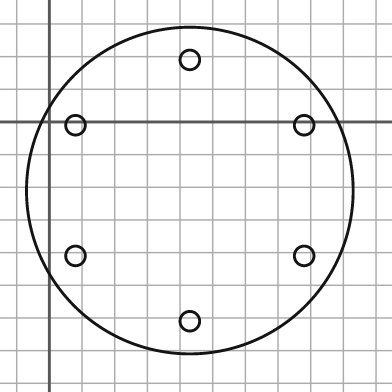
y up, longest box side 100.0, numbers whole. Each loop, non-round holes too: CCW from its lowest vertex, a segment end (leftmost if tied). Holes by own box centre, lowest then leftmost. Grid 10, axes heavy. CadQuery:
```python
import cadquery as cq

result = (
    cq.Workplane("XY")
    .moveTo(43.0, -21.0)
    .circle(50.0)
    .moveTo(43.0, -61.0)
    .circle(3.0)
    .moveTo(8.0, -41.0)
    .circle(3.0)
    .moveTo(78.0, -41.0)
    .circle(3.0)
    .moveTo(8.0, -1.0)
    .circle(3.0)
    .moveTo(78.0, -1.0)
    .circle(3.0)
    .moveTo(43.0, 19.0)
    .circle(3.0)
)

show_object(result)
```